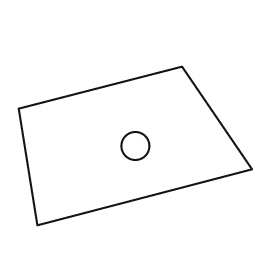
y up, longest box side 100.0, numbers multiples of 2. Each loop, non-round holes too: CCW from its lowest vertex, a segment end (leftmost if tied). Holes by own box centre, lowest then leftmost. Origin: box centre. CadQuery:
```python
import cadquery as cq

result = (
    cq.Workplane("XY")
    .moveTo(-42.0, -34.0)
    .lineTo(50.0, -10.0)
    .lineTo(20.0, 34.0)
    .lineTo(-50.0, 16.0)
    .close()
    .moveTo(0.0, 0.0)
    .circle(6.0)
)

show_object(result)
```